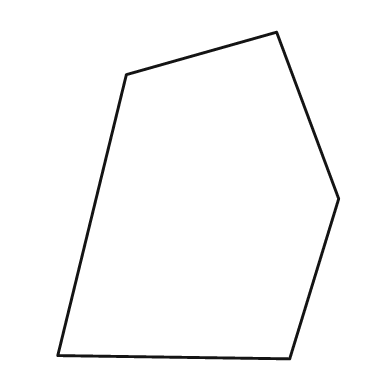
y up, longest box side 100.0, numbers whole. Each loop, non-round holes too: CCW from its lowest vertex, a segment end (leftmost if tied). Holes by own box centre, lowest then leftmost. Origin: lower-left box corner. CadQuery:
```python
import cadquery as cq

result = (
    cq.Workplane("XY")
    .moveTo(71.0, 0.0)
    .lineTo(86.0, 49.0)
    .lineTo(67.0, 100.0)
    .lineTo(21.0, 87.0)
    .lineTo(0.0, 1.0)
    .close()
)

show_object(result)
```